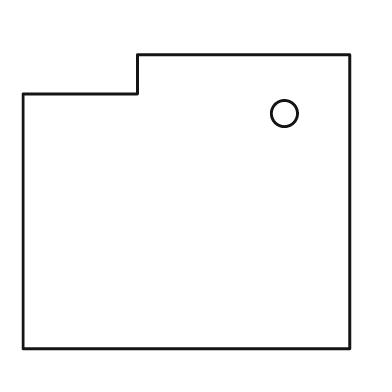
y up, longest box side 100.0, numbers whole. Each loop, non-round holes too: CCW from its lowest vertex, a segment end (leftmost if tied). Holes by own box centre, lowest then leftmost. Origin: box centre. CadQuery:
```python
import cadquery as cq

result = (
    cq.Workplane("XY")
    .moveTo(-50.0, -45.0)
    .lineTo(50.0, -45.0)
    .lineTo(50.0, 45.0)
    .lineTo(-15.0, 45.0)
    .lineTo(-15.0, 33.0)
    .lineTo(-50.0, 33.0)
    .close()
    .moveTo(30.0, 27.0)
    .circle(4.0)
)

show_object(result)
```